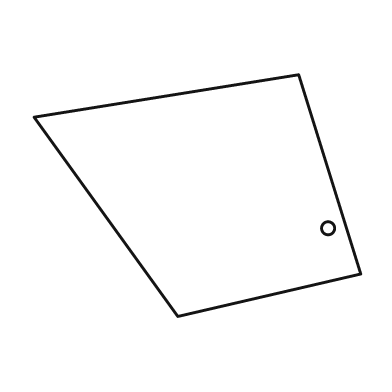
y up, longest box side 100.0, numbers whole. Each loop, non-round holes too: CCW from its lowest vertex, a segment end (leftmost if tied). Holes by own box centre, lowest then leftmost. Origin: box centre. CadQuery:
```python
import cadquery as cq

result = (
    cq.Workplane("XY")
    .moveTo(-6.0, -37.0)
    .lineTo(50.0, -24.0)
    .lineTo(31.0, 37.0)
    .lineTo(-50.0, 24.0)
    .close()
    .moveTo(40.0, -10.0)
    .circle(2.0)
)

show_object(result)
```